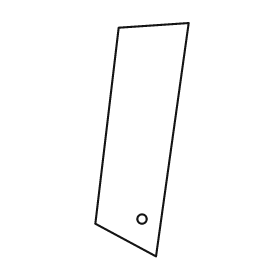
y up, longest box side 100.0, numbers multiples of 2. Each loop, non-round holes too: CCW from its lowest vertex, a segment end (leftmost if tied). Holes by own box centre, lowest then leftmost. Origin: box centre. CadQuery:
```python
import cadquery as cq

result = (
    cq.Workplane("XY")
    .moveTo(6.0, -50.0)
    .lineTo(20.0, 50.0)
    .lineTo(-10.0, 48.0)
    .lineTo(-20.0, -36.0)
    .close()
    .moveTo(0.0, -34.0)
    .circle(2.0)
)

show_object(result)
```